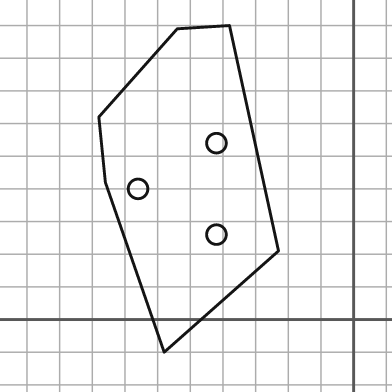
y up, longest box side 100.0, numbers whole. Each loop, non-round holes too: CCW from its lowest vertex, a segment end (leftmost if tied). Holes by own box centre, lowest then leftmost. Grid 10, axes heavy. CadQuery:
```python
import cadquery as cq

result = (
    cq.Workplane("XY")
    .moveTo(-58.0, -10.0)
    .lineTo(-23.0, 21.0)
    .lineTo(-38.0, 90.0)
    .lineTo(-54.0, 89.0)
    .lineTo(-78.0, 62.0)
    .lineTo(-76.0, 42.0)
    .close()
    .moveTo(-42.0, 26.0)
    .circle(3.0)
    .moveTo(-66.0, 40.0)
    .circle(3.0)
    .moveTo(-42.0, 54.0)
    .circle(3.0)
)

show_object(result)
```